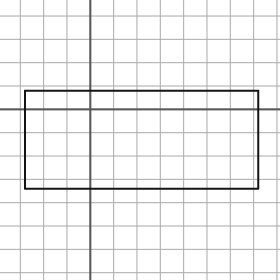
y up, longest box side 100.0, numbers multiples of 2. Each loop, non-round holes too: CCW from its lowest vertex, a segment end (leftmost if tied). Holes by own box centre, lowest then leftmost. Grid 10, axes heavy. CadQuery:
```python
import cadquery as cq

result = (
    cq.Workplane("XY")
    .moveTo(-28.0, -34.0)
    .lineTo(72.0, -34.0)
    .lineTo(72.0, 8.0)
    .lineTo(-28.0, 8.0)
    .close()
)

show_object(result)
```